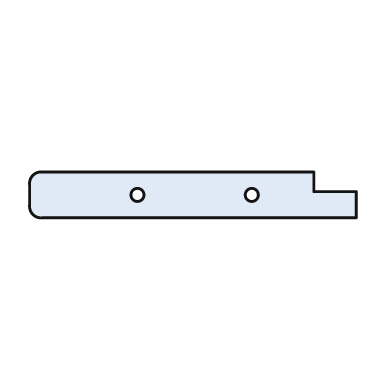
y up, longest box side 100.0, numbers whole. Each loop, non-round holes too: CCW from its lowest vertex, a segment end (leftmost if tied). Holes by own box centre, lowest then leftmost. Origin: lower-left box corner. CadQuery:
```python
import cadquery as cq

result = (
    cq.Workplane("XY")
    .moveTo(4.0, 0.0)
    .lineTo(100.0, 0.0)
    .lineTo(100.0, 8.0)
    .lineTo(87.0, 8.0)
    .lineTo(87.0, 14.0)
    .lineTo(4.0, 14.0)
    .threePointArc((1.0, 13.0), (0.0, 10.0))
    .lineTo(0.0, 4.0)
    .threePointArc((1.0, 1.0), (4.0, 0.0))
    .close()
    .moveTo(33.0, 7.0)
    .circle(2.0)
    .moveTo(68.0, 7.0)
    .circle(2.0)
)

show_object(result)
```